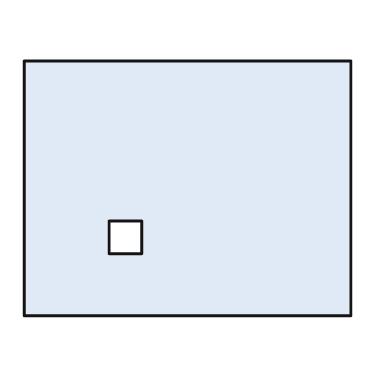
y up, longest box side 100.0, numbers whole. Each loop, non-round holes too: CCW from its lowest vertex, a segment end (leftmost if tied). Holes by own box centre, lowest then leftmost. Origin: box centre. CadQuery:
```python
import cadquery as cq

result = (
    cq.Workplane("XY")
    .moveTo(-50.0, -39.0)
    .lineTo(50.0, -39.0)
    .lineTo(50.0, 39.0)
    .lineTo(-50.0, 39.0)
    .close()
    .moveTo(-24.0, -20.0)
    .lineTo(-14.0, -20.0)
    .lineTo(-14.0, -10.0)
    .lineTo(-24.0, -10.0)
    .close()
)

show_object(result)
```